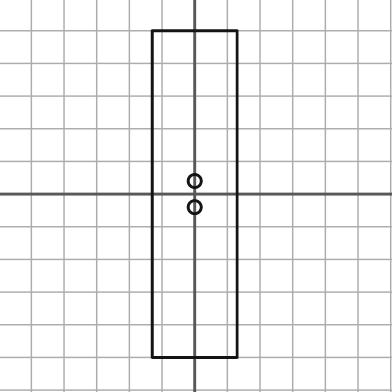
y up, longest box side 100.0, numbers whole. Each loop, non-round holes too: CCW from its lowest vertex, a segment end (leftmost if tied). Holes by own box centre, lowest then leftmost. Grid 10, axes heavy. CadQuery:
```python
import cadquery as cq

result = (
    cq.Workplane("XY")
    .moveTo(-13.0, -50.0)
    .lineTo(13.0, -50.0)
    .lineTo(13.0, 50.0)
    .lineTo(-13.0, 50.0)
    .close()
    .moveTo(0.0, -4.0)
    .circle(2.0)
    .moveTo(0.0, 4.0)
    .circle(2.0)
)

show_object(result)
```